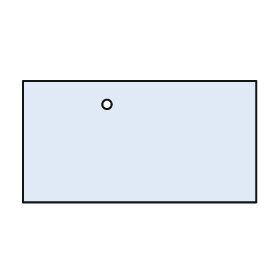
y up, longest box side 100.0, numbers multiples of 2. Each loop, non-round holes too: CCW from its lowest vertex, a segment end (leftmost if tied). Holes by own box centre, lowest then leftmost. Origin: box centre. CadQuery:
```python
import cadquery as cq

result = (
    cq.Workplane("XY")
    .moveTo(-50.0, -26.0)
    .lineTo(50.0, -26.0)
    .lineTo(50.0, 26.0)
    .lineTo(-50.0, 26.0)
    .close()
    .moveTo(-14.0, 16.0)
    .circle(2.0)
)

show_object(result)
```